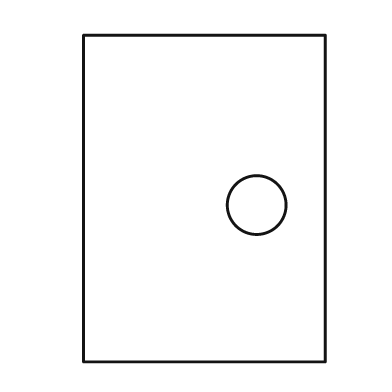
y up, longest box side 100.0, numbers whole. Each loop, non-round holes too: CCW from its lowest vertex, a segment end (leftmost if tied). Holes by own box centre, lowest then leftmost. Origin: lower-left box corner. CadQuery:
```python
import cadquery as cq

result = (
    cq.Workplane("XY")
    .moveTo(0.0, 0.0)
    .lineTo(74.0, 0.0)
    .lineTo(74.0, 100.0)
    .lineTo(0.0, 100.0)
    .close()
    .moveTo(53.0, 48.0)
    .circle(9.0)
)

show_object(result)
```